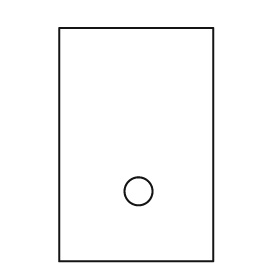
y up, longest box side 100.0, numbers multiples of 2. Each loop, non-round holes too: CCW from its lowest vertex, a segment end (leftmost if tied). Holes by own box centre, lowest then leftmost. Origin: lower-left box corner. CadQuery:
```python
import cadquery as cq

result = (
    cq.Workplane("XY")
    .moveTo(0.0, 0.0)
    .lineTo(66.0, 0.0)
    .lineTo(66.0, 100.0)
    .lineTo(0.0, 100.0)
    .close()
    .moveTo(34.0, 30.0)
    .circle(6.0)
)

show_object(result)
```